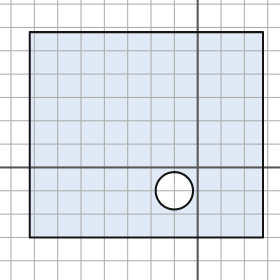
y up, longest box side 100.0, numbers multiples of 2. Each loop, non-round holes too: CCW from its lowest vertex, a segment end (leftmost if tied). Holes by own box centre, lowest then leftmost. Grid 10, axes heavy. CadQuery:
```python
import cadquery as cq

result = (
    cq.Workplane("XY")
    .moveTo(-72.0, -30.0)
    .lineTo(28.0, -30.0)
    .lineTo(28.0, 58.0)
    .lineTo(-72.0, 58.0)
    .close()
    .moveTo(-10.0, -10.0)
    .circle(8.0)
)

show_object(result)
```